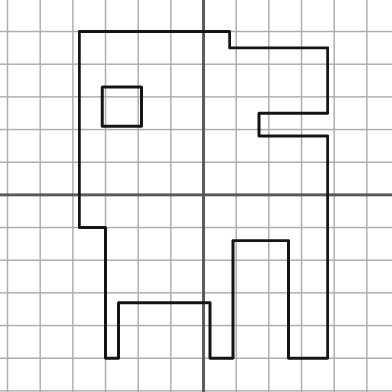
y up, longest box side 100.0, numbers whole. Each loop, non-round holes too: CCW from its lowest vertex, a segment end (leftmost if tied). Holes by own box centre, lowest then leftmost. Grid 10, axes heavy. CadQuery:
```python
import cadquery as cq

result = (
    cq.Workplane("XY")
    .moveTo(-30.0, -50.0)
    .lineTo(-26.0, -50.0)
    .lineTo(-26.0, -33.0)
    .lineTo(2.0, -33.0)
    .lineTo(2.0, -50.0)
    .lineTo(9.0, -50.0)
    .lineTo(9.0, -14.0)
    .lineTo(26.0, -14.0)
    .lineTo(26.0, -50.0)
    .lineTo(38.0, -50.0)
    .lineTo(38.0, 18.0)
    .lineTo(17.0, 18.0)
    .lineTo(17.0, 25.0)
    .lineTo(38.0, 25.0)
    .lineTo(38.0, 45.0)
    .lineTo(8.0, 45.0)
    .lineTo(8.0, 50.0)
    .lineTo(-38.0, 50.0)
    .lineTo(-38.0, -10.0)
    .lineTo(-30.0, -10.0)
    .close()
    .moveTo(-31.0, 21.0)
    .lineTo(-19.0, 21.0)
    .lineTo(-19.0, 33.0)
    .lineTo(-31.0, 33.0)
    .close()
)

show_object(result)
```